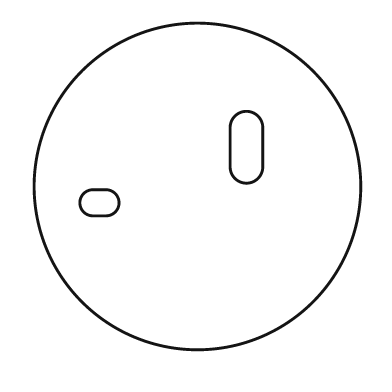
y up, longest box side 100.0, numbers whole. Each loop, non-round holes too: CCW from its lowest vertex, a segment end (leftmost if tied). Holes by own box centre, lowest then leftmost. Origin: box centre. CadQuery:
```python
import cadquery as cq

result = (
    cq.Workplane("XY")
    .moveTo(0.0, 0.0)
    .circle(50.0)
    .moveTo(-32.0, -9.0)
    .lineTo(-28.0, -9.0)
    .threePointArc((-24.0, -5.0), (-28.0, -1.0))
    .lineTo(-32.0, -1.0)
    .threePointArc((-36.0, -5.0), (-32.0, -9.0))
    .close()
    .moveTo(10.0, 6.0)
    .threePointArc((15.0, 1.0), (20.0, 6.0))
    .lineTo(20.0, 18.0)
    .threePointArc((15.0, 23.0), (10.0, 18.0))
    .close()
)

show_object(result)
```